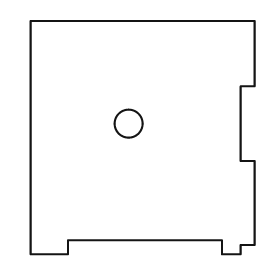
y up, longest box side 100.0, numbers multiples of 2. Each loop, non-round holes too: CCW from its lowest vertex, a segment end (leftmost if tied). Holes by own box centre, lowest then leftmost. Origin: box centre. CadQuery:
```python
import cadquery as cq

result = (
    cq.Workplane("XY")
    .moveTo(-48.0, -50.0)
    .lineTo(-32.0, -50.0)
    .lineTo(-32.0, -44.0)
    .lineTo(34.0, -44.0)
    .lineTo(34.0, -50.0)
    .lineTo(42.0, -50.0)
    .lineTo(42.0, -46.0)
    .lineTo(48.0, -46.0)
    .lineTo(48.0, -10.0)
    .lineTo(42.0, -10.0)
    .lineTo(42.0, 22.0)
    .lineTo(48.0, 22.0)
    .lineTo(48.0, 50.0)
    .lineTo(-48.0, 50.0)
    .close()
    .moveTo(-6.0, 6.0)
    .circle(6.0)
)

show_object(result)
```